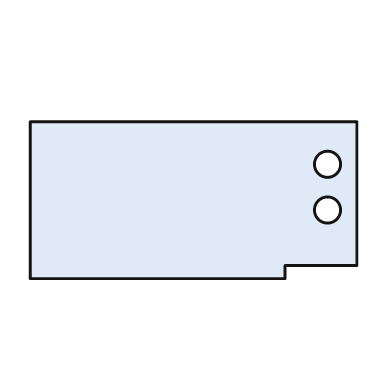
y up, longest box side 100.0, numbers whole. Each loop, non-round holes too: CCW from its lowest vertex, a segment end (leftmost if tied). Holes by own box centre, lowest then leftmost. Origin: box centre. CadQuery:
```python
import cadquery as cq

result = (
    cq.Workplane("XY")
    .moveTo(-50.0, -24.0)
    .lineTo(28.0, -24.0)
    .lineTo(28.0, -20.0)
    .lineTo(50.0, -20.0)
    .lineTo(50.0, 24.0)
    .lineTo(-50.0, 24.0)
    .close()
    .moveTo(41.0, -3.0)
    .circle(4.0)
    .moveTo(41.0, 11.0)
    .circle(4.0)
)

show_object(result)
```